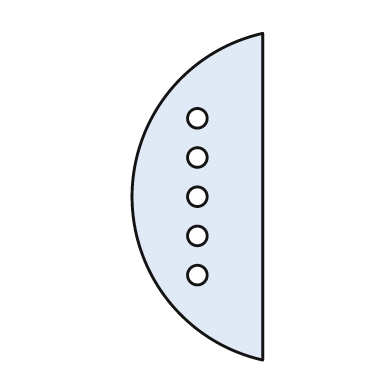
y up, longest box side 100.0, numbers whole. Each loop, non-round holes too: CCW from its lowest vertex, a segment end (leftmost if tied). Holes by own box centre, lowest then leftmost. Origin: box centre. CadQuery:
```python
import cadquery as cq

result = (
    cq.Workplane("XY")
    .moveTo(20.0, -50.0)
    .lineTo(20.0, 50.0)
    .threePointArc((-20.0, 0.0), (20.0, -50.0))
    .close()
    .moveTo(0.0, -24.0)
    .circle(3.0)
    .moveTo(0.0, -12.0)
    .circle(3.0)
    .moveTo(0.0, 0.0)
    .circle(3.0)
    .moveTo(0.0, 12.0)
    .circle(3.0)
    .moveTo(0.0, 24.0)
    .circle(3.0)
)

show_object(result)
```